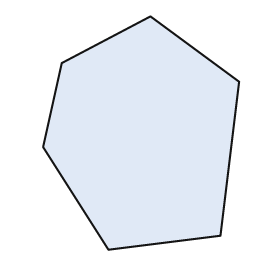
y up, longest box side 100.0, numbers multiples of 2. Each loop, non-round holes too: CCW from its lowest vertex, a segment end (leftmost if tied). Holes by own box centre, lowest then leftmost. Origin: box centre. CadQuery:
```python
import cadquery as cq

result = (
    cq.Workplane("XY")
    .moveTo(-14.0, -50.0)
    .lineTo(34.0, -44.0)
    .lineTo(42.0, 22.0)
    .lineTo(4.0, 50.0)
    .lineTo(-34.0, 30.0)
    .lineTo(-42.0, -6.0)
    .close()
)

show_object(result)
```